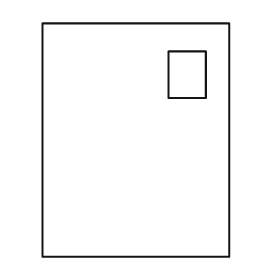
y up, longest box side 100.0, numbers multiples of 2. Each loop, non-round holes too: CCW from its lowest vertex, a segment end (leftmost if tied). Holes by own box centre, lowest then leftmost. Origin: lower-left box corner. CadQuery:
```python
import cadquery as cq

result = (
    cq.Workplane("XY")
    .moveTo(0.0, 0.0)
    .lineTo(80.0, 0.0)
    .lineTo(80.0, 100.0)
    .lineTo(0.0, 100.0)
    .close()
    .moveTo(54.0, 68.0)
    .lineTo(70.0, 68.0)
    .lineTo(70.0, 88.0)
    .lineTo(54.0, 88.0)
    .close()
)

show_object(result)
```